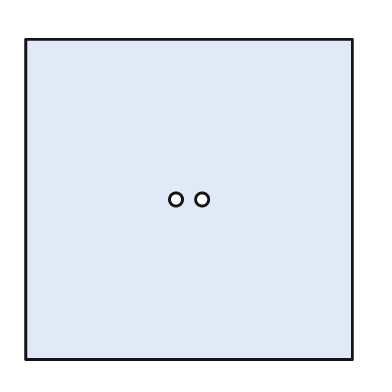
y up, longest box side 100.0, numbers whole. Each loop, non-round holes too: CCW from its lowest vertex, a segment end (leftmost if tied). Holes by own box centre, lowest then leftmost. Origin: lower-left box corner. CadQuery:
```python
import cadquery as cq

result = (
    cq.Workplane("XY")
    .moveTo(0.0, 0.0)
    .lineTo(100.0, 0.0)
    .lineTo(100.0, 98.0)
    .lineTo(0.0, 98.0)
    .close()
    .moveTo(46.0, 49.0)
    .circle(2.0)
    .moveTo(54.0, 49.0)
    .circle(2.0)
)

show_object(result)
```